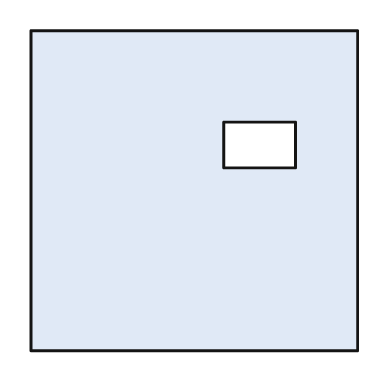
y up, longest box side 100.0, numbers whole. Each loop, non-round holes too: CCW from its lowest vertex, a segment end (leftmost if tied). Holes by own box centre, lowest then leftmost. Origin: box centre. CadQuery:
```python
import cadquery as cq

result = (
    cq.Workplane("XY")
    .moveTo(-50.0, -49.0)
    .lineTo(50.0, -49.0)
    .lineTo(50.0, 49.0)
    .lineTo(-50.0, 49.0)
    .close()
    .moveTo(9.0, 7.0)
    .lineTo(31.0, 7.0)
    .lineTo(31.0, 21.0)
    .lineTo(9.0, 21.0)
    .close()
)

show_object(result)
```